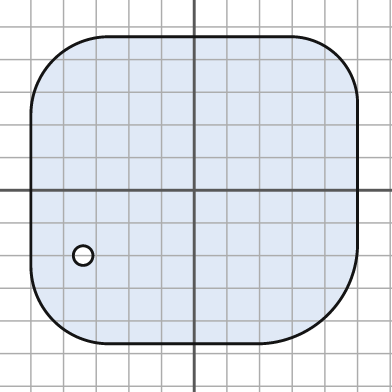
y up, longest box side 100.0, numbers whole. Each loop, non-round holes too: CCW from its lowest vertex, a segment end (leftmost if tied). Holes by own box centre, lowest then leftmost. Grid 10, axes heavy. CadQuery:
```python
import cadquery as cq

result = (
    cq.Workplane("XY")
    .moveTo(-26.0, -47.0)
    .lineTo(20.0, -47.0)
    .threePointArc((41.0, -38.0), (50.0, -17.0))
    .lineTo(50.0, 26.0)
    .threePointArc((44.0, 41.0), (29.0, 47.0))
    .lineTo(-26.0, 47.0)
    .threePointArc((-43.0, 40.0), (-50.0, 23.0))
    .lineTo(-50.0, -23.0)
    .threePointArc((-43.0, -40.0), (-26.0, -47.0))
    .close()
    .moveTo(-34.0, -20.0)
    .circle(3.0)
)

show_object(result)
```